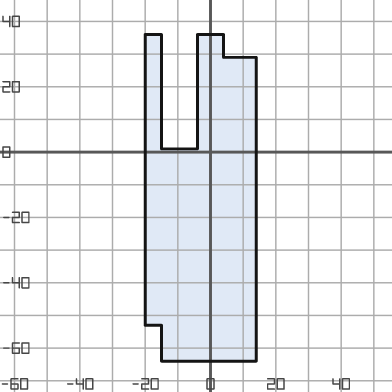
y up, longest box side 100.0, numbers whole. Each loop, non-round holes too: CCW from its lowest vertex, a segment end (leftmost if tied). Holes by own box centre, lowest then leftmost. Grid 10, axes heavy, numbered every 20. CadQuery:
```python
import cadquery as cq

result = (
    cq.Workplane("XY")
    .moveTo(-15.0, -64.0)
    .lineTo(14.0, -64.0)
    .lineTo(14.0, 29.0)
    .lineTo(4.0, 29.0)
    .lineTo(4.0, 36.0)
    .lineTo(-4.0, 36.0)
    .lineTo(-4.0, 1.0)
    .lineTo(-15.0, 1.0)
    .lineTo(-15.0, 36.0)
    .lineTo(-20.0, 36.0)
    .lineTo(-20.0, -53.0)
    .lineTo(-15.0, -53.0)
    .close()
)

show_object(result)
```